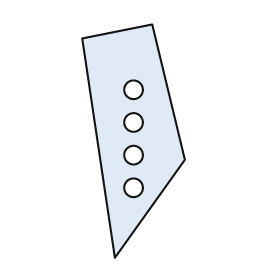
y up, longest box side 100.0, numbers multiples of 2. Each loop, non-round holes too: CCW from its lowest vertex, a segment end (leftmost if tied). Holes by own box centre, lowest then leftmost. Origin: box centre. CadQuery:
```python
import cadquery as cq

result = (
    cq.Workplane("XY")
    .moveTo(-8.0, -50.0)
    .lineTo(22.0, -8.0)
    .lineTo(8.0, 50.0)
    .lineTo(-22.0, 44.0)
    .close()
    .moveTo(0.0, -20.0)
    .circle(4.0)
    .moveTo(0.0, -6.0)
    .circle(4.0)
    .moveTo(0.0, 8.0)
    .circle(4.0)
    .moveTo(0.0, 22.0)
    .circle(4.0)
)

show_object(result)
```